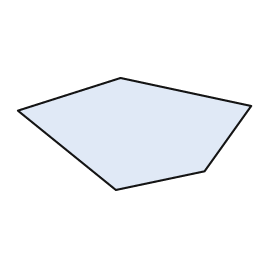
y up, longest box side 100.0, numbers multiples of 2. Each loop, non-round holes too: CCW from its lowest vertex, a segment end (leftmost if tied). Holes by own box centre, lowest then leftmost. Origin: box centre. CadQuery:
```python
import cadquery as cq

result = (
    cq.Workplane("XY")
    .moveTo(-8.0, -24.0)
    .lineTo(30.0, -16.0)
    .lineTo(50.0, 12.0)
    .lineTo(-6.0, 24.0)
    .lineTo(-50.0, 10.0)
    .close()
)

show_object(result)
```